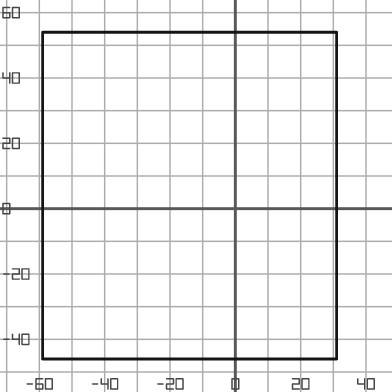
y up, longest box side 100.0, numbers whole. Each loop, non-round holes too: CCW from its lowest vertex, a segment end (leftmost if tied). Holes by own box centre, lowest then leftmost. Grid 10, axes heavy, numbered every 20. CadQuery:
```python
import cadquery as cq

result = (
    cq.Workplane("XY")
    .moveTo(-59.0, -46.0)
    .lineTo(31.0, -46.0)
    .lineTo(31.0, 54.0)
    .lineTo(-59.0, 54.0)
    .close()
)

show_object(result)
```